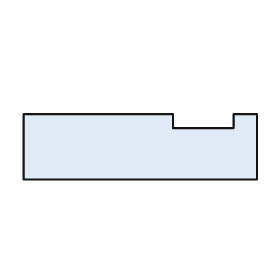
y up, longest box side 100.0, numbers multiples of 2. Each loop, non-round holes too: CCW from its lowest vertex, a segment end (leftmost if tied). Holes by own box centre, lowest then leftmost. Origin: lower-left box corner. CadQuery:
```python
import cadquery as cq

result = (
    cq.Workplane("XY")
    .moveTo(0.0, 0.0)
    .lineTo(100.0, 0.0)
    .lineTo(100.0, 28.0)
    .lineTo(90.0, 28.0)
    .lineTo(90.0, 22.0)
    .lineTo(64.0, 22.0)
    .lineTo(64.0, 28.0)
    .lineTo(0.0, 28.0)
    .close()
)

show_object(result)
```